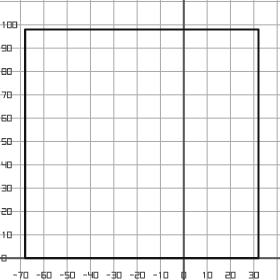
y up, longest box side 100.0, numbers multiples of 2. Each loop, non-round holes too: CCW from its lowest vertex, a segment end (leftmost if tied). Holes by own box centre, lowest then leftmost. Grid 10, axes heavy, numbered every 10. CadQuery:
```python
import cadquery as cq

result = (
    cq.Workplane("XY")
    .moveTo(-68.0, 0.0)
    .lineTo(32.0, 0.0)
    .lineTo(32.0, 98.0)
    .lineTo(-68.0, 98.0)
    .close()
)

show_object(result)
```